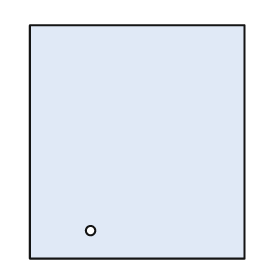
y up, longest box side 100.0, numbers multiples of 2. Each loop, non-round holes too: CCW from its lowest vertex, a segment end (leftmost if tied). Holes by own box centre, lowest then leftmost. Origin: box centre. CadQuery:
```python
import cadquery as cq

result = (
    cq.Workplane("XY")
    .moveTo(-46.0, -50.0)
    .lineTo(46.0, -50.0)
    .lineTo(46.0, 50.0)
    .lineTo(-46.0, 50.0)
    .close()
    .moveTo(-20.0, -38.0)
    .circle(2.0)
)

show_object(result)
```